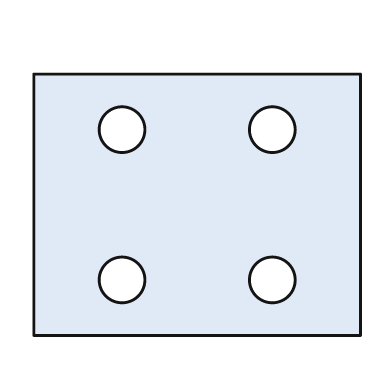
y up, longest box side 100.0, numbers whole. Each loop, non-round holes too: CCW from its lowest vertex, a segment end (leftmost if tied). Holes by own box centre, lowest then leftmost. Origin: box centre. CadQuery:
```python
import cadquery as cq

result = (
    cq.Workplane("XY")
    .moveTo(-50.0, -40.0)
    .lineTo(50.0, -40.0)
    .lineTo(50.0, 40.0)
    .lineTo(-50.0, 40.0)
    .close()
    .moveTo(-23.0, -23.0)
    .circle(7.0)
    .moveTo(23.0, -23.0)
    .circle(7.0)
    .moveTo(-23.0, 23.0)
    .circle(7.0)
    .moveTo(23.0, 23.0)
    .circle(7.0)
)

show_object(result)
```